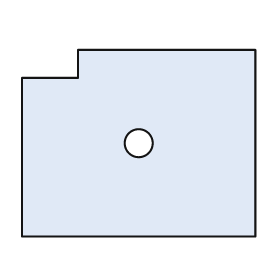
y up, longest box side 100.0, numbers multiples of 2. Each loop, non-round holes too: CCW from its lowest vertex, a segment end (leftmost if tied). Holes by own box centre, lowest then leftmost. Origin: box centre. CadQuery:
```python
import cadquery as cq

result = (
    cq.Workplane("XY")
    .moveTo(-50.0, -40.0)
    .lineTo(50.0, -40.0)
    .lineTo(50.0, 40.0)
    .lineTo(-26.0, 40.0)
    .lineTo(-26.0, 28.0)
    .lineTo(-50.0, 28.0)
    .close()
    .moveTo(0.0, 0.0)
    .circle(6.0)
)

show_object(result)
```